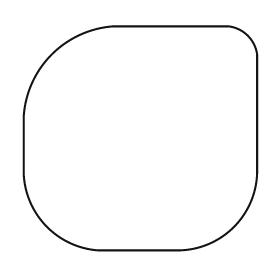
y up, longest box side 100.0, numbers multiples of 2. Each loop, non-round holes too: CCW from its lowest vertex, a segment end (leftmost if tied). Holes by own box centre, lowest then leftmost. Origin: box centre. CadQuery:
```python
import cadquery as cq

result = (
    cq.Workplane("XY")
    .moveTo(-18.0, -48.0)
    .lineTo(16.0, -48.0)
    .threePointArc((40.0, -38.0), (50.0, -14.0))
    .lineTo(50.0, 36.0)
    .threePointArc((46.0, 44.0), (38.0, 48.0))
    .lineTo(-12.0, 48.0)
    .threePointArc((-38.0, 36.0), (-50.0, 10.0))
    .lineTo(-50.0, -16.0)
    .threePointArc((-40.0, -38.0), (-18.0, -48.0))
    .close()
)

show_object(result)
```